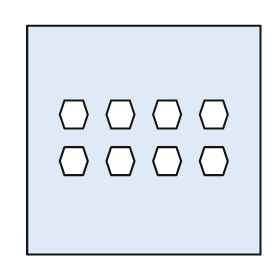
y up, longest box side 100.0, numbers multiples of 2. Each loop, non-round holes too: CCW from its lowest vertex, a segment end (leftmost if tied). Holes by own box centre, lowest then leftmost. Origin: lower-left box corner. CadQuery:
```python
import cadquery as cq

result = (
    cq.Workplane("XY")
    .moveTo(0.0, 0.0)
    .lineTo(100.0, 0.0)
    .lineTo(100.0, 98.0)
    .lineTo(0.0, 98.0)
    .close()
    .moveTo(16.0, 34.0)
    .lineTo(24.0, 34.0)
    .lineTo(26.0, 40.0)
    .lineTo(24.0, 46.0)
    .lineTo(16.0, 46.0)
    .lineTo(14.0, 40.0)
    .close()
    .moveTo(36.0, 34.0)
    .lineTo(44.0, 34.0)
    .lineTo(46.0, 40.0)
    .lineTo(44.0, 46.0)
    .lineTo(36.0, 46.0)
    .lineTo(34.0, 40.0)
    .close()
    .moveTo(56.0, 34.0)
    .lineTo(64.0, 34.0)
    .lineTo(66.0, 40.0)
    .lineTo(64.0, 46.0)
    .lineTo(56.0, 46.0)
    .lineTo(54.0, 40.0)
    .close()
    .moveTo(76.0, 34.0)
    .lineTo(84.0, 34.0)
    .lineTo(86.0, 40.0)
    .lineTo(84.0, 46.0)
    .lineTo(76.0, 46.0)
    .lineTo(74.0, 40.0)
    .close()
    .moveTo(16.0, 54.0)
    .lineTo(24.0, 54.0)
    .lineTo(26.0, 60.0)
    .lineTo(24.0, 66.0)
    .lineTo(16.0, 66.0)
    .lineTo(14.0, 60.0)
    .close()
    .moveTo(36.0, 54.0)
    .lineTo(44.0, 54.0)
    .lineTo(46.0, 60.0)
    .lineTo(44.0, 66.0)
    .lineTo(36.0, 66.0)
    .lineTo(34.0, 60.0)
    .close()
    .moveTo(56.0, 54.0)
    .lineTo(64.0, 54.0)
    .lineTo(66.0, 60.0)
    .lineTo(64.0, 66.0)
    .lineTo(56.0, 66.0)
    .lineTo(54.0, 60.0)
    .close()
    .moveTo(76.0, 54.0)
    .lineTo(84.0, 54.0)
    .lineTo(86.0, 60.0)
    .lineTo(84.0, 66.0)
    .lineTo(76.0, 66.0)
    .lineTo(74.0, 60.0)
    .close()
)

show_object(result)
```